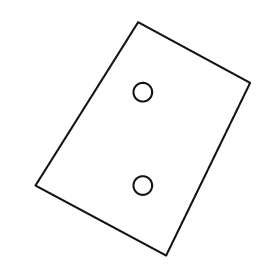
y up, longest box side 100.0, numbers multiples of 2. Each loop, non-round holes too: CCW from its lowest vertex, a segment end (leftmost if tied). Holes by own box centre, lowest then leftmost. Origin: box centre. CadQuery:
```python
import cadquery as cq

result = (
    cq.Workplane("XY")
    .moveTo(10.0, -50.0)
    .lineTo(46.0, 24.0)
    .lineTo(-2.0, 50.0)
    .lineTo(-46.0, -20.0)
    .close()
    .moveTo(0.0, -20.0)
    .circle(4.0)
    .moveTo(0.0, 20.0)
    .circle(4.0)
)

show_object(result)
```